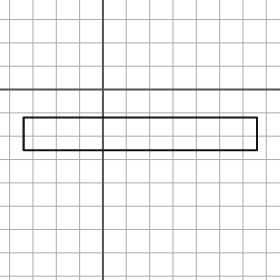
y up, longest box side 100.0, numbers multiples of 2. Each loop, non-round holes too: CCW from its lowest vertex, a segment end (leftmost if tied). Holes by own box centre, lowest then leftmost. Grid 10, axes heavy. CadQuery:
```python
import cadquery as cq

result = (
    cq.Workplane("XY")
    .moveTo(-34.0, -26.0)
    .lineTo(66.0, -26.0)
    .lineTo(66.0, -12.0)
    .lineTo(-34.0, -12.0)
    .close()
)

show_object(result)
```